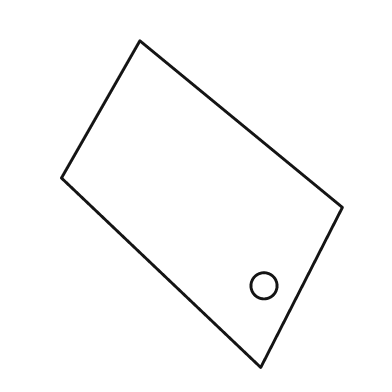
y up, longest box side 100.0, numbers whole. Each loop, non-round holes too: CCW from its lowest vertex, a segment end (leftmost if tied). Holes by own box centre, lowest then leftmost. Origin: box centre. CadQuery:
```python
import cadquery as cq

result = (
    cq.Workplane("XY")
    .moveTo(18.0, -50.0)
    .lineTo(43.0, -1.0)
    .lineTo(-19.0, 50.0)
    .lineTo(-43.0, 8.0)
    .close()
    .moveTo(19.0, -25.0)
    .circle(4.0)
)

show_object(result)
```